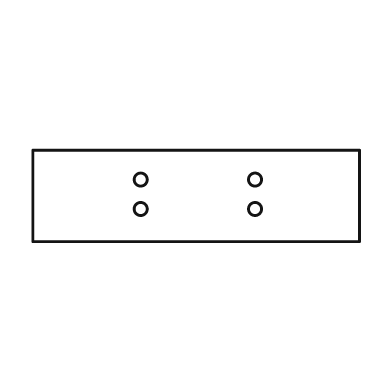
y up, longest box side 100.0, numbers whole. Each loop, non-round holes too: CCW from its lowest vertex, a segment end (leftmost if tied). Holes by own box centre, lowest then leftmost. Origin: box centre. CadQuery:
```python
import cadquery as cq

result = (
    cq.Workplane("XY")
    .moveTo(-50.0, -14.0)
    .lineTo(50.0, -14.0)
    .lineTo(50.0, 14.0)
    .lineTo(-50.0, 14.0)
    .close()
    .moveTo(-17.0, -4.0)
    .circle(2.0)
    .moveTo(18.0, -4.0)
    .circle(2.0)
    .moveTo(-17.0, 5.0)
    .circle(2.0)
    .moveTo(18.0, 5.0)
    .circle(2.0)
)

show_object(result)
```